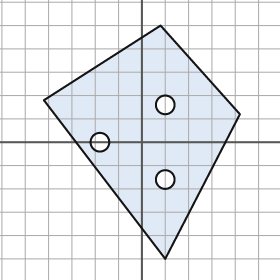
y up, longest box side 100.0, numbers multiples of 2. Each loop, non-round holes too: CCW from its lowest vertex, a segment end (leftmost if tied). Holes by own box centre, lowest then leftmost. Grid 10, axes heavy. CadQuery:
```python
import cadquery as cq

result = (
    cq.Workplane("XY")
    .moveTo(10.0, -50.0)
    .lineTo(42.0, 12.0)
    .lineTo(8.0, 50.0)
    .lineTo(-42.0, 18.0)
    .close()
    .moveTo(10.0, -16.0)
    .circle(4.0)
    .moveTo(-18.0, 0.0)
    .circle(4.0)
    .moveTo(10.0, 16.0)
    .circle(4.0)
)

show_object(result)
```